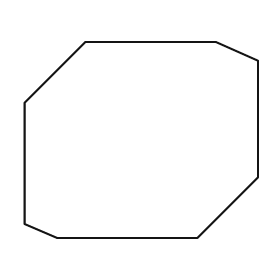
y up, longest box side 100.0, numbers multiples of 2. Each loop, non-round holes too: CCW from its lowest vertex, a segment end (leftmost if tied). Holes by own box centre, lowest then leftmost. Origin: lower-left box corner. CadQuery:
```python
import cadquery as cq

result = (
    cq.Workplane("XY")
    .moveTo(14.0, 0.0)
    .lineTo(74.0, 0.0)
    .lineTo(100.0, 26.0)
    .lineTo(100.0, 76.0)
    .lineTo(82.0, 84.0)
    .lineTo(26.0, 84.0)
    .lineTo(0.0, 58.0)
    .lineTo(0.0, 6.0)
    .close()
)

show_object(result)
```